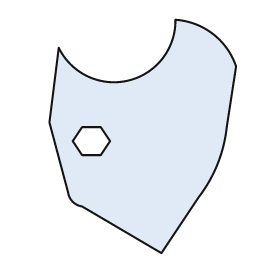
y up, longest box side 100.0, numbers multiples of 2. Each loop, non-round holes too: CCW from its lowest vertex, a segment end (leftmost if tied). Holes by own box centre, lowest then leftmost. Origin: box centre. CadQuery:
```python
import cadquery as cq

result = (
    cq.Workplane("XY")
    .moveTo(8.0, -50.0)
    .lineTo(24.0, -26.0)
    .threePointArc((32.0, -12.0), (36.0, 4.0))
    .lineTo(40.0, 30.0)
    .threePointArc((30.0, 44.0), (14.0, 50.0))
    .threePointArc((-6.0, 24.0), (-36.0, 38.0))
    .lineTo(-40.0, 6.0)
    .lineTo(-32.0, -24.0)
    .threePointArc((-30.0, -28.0), (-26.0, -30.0))
    .close()
    .moveTo(-26.0, -8.0)
    .lineTo(-18.0, -8.0)
    .lineTo(-14.0, -2.0)
    .lineTo(-18.0, 4.0)
    .lineTo(-26.0, 4.0)
    .lineTo(-30.0, -2.0)
    .close()
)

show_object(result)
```